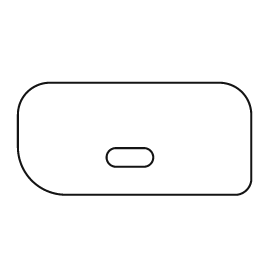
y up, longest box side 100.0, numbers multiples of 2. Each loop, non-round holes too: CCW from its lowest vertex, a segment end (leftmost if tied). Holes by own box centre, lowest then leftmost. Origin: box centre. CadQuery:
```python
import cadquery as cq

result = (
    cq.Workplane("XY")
    .moveTo(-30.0, -24.0)
    .lineTo(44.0, -24.0)
    .threePointArc((48.0, -22.0), (50.0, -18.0))
    .lineTo(50.0, 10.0)
    .threePointArc((46.0, 20.0), (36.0, 24.0))
    .lineTo(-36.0, 24.0)
    .threePointArc((-46.0, 20.0), (-50.0, 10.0))
    .lineTo(-50.0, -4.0)
    .threePointArc((-44.0, -18.0), (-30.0, -24.0))
    .close()
    .moveTo(-8.0, -12.0)
    .lineTo(4.0, -12.0)
    .threePointArc((8.0, -8.0), (4.0, -4.0))
    .lineTo(-8.0, -4.0)
    .threePointArc((-12.0, -8.0), (-8.0, -12.0))
    .close()
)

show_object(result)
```